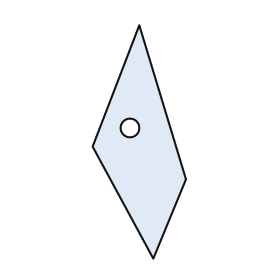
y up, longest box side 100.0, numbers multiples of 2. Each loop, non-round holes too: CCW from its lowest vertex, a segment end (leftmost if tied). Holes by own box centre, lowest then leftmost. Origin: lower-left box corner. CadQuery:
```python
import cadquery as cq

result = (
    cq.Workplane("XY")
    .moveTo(26.0, 0.0)
    .lineTo(40.0, 34.0)
    .lineTo(20.0, 100.0)
    .lineTo(0.0, 48.0)
    .close()
    .moveTo(16.0, 56.0)
    .circle(4.0)
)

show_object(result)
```